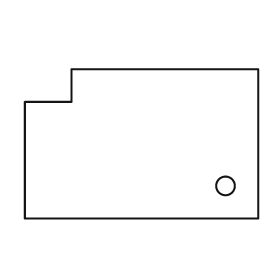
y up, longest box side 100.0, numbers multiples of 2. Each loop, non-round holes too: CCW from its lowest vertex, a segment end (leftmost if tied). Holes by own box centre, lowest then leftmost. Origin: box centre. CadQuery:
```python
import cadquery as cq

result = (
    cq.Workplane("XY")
    .moveTo(-50.0, -32.0)
    .lineTo(50.0, -32.0)
    .lineTo(50.0, 32.0)
    .lineTo(-30.0, 32.0)
    .lineTo(-30.0, 18.0)
    .lineTo(-50.0, 18.0)
    .close()
    .moveTo(36.0, -18.0)
    .circle(4.0)
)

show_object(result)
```